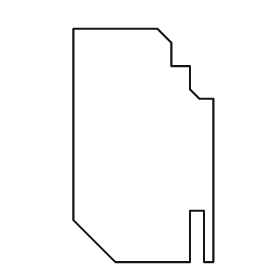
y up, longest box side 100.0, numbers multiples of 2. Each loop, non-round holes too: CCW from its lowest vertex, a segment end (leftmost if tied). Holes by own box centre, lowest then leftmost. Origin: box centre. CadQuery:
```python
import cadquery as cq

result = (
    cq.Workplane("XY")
    .moveTo(-12.0, -50.0)
    .lineTo(20.0, -50.0)
    .lineTo(20.0, -28.0)
    .lineTo(26.0, -28.0)
    .lineTo(26.0, -50.0)
    .lineTo(30.0, -50.0)
    .lineTo(30.0, 20.0)
    .lineTo(24.0, 20.0)
    .lineTo(20.0, 24.0)
    .lineTo(20.0, 34.0)
    .lineTo(12.0, 34.0)
    .lineTo(12.0, 44.0)
    .lineTo(6.0, 50.0)
    .lineTo(-30.0, 50.0)
    .lineTo(-30.0, -32.0)
    .close()
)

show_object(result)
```